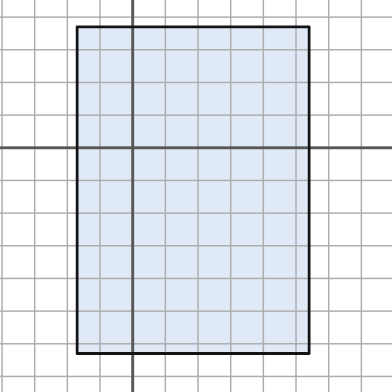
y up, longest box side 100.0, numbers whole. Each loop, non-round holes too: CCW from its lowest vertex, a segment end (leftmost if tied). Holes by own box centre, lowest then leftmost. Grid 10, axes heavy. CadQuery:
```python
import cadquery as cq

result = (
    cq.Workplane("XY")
    .moveTo(-17.0, -63.0)
    .lineTo(54.0, -63.0)
    .lineTo(54.0, 37.0)
    .lineTo(-17.0, 37.0)
    .close()
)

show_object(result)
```